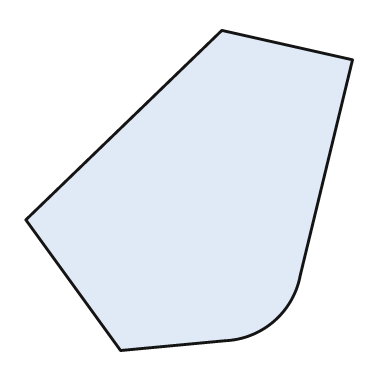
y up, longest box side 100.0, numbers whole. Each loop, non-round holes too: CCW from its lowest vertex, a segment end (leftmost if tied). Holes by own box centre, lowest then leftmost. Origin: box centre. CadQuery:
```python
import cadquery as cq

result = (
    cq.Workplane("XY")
    .moveTo(-21.0, -49.0)
    .lineTo(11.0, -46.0)
    .threePointArc((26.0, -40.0), (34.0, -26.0))
    .lineTo(50.0, 40.0)
    .lineTo(10.0, 49.0)
    .lineTo(-50.0, -9.0)
    .close()
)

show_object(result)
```